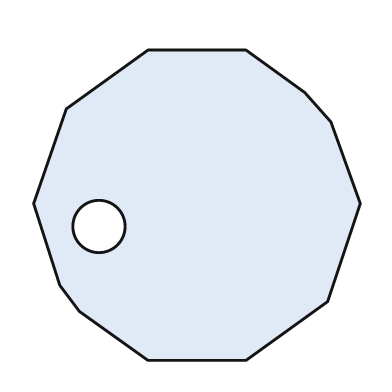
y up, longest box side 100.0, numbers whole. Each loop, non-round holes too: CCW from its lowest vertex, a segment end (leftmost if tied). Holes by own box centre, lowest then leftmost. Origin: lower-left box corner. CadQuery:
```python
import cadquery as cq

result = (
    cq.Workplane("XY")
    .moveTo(35.0, 0.0)
    .lineTo(65.0, 0.0)
    .lineTo(90.0, 18.0)
    .lineTo(100.0, 48.0)
    .lineTo(91.0, 73.0)
    .lineTo(83.0, 82.0)
    .lineTo(65.0, 95.0)
    .lineTo(35.0, 95.0)
    .lineTo(10.0, 77.0)
    .lineTo(0.0, 48.0)
    .lineTo(8.0, 23.0)
    .lineTo(14.0, 15.0)
    .close()
    .moveTo(20.0, 41.0)
    .circle(8.0)
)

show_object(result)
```